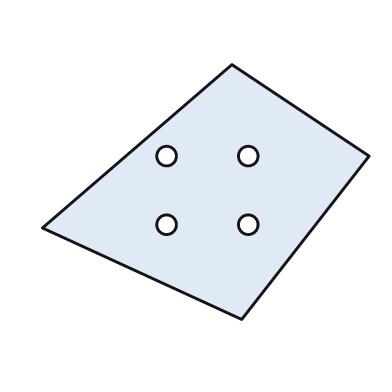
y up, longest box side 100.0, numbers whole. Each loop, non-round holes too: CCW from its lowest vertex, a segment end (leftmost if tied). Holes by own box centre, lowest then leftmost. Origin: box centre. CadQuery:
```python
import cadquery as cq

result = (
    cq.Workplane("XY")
    .moveTo(11.0, -39.0)
    .lineTo(50.0, 11.0)
    .lineTo(8.0, 39.0)
    .lineTo(-50.0, -11.0)
    .close()
    .moveTo(-12.0, -10.0)
    .circle(3.0)
    .moveTo(13.0, -10.0)
    .circle(3.0)
    .moveTo(-12.0, 11.0)
    .circle(3.0)
    .moveTo(13.0, 11.0)
    .circle(3.0)
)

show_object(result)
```